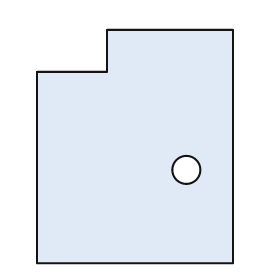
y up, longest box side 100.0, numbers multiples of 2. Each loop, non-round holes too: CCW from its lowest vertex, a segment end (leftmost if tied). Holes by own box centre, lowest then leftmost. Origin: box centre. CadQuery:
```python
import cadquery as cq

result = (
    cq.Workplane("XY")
    .moveTo(-42.0, -50.0)
    .lineTo(42.0, -50.0)
    .lineTo(42.0, 50.0)
    .lineTo(-12.0, 50.0)
    .lineTo(-12.0, 32.0)
    .lineTo(-42.0, 32.0)
    .close()
    .moveTo(22.0, -10.0)
    .circle(6.0)
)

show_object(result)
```